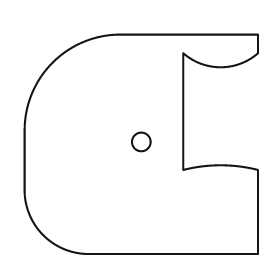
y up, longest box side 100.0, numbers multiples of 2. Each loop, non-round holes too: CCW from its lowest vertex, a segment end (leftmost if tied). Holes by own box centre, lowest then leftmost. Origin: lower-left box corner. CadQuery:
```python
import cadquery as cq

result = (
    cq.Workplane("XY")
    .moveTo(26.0, 0.0)
    .lineTo(100.0, 0.0)
    .lineTo(100.0, 36.0)
    .threePointArc((84.0, 38.0), (68.0, 36.0))
    .lineTo(68.0, 86.0)
    .threePointArc((84.0, 80.0), (100.0, 86.0))
    .lineTo(100.0, 94.0)
    .lineTo(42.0, 94.0)
    .threePointArc((12.0, 82.0), (0.0, 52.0))
    .lineTo(0.0, 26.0)
    .threePointArc((8.0, 8.0), (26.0, 0.0))
    .close()
    .moveTo(50.0, 48.0)
    .circle(4.0)
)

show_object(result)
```